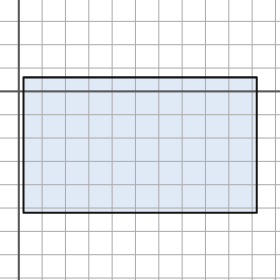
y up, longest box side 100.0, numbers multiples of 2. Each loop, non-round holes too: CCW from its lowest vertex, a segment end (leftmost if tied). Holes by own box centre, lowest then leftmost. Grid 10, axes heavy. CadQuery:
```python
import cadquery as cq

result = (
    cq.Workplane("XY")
    .moveTo(2.0, -52.0)
    .lineTo(102.0, -52.0)
    .lineTo(102.0, 6.0)
    .lineTo(2.0, 6.0)
    .close()
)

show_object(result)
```